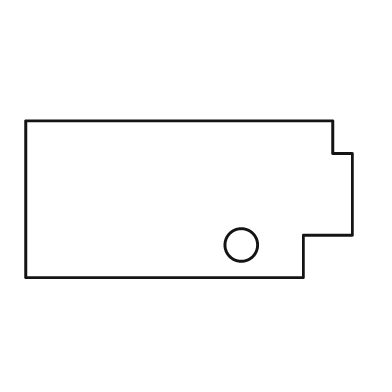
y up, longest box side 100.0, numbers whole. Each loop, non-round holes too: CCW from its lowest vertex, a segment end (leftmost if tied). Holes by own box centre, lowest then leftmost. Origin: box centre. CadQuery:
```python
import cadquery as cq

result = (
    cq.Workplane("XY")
    .moveTo(-50.0, -24.0)
    .lineTo(35.0, -24.0)
    .lineTo(35.0, -11.0)
    .lineTo(50.0, -11.0)
    .lineTo(50.0, 14.0)
    .lineTo(44.0, 14.0)
    .lineTo(44.0, 24.0)
    .lineTo(-50.0, 24.0)
    .close()
    .moveTo(16.0, -14.0)
    .circle(5.0)
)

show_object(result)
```